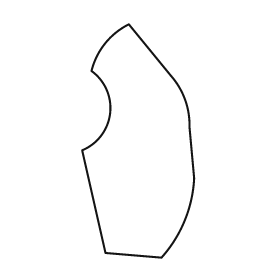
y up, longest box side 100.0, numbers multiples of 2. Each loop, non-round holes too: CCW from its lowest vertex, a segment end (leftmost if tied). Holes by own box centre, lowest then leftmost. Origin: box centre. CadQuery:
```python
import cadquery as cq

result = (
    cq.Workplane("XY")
    .moveTo(10.0, -50.0)
    .threePointArc((20.0, -34.0), (24.0, -16.0))
    .lineTo(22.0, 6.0)
    .threePointArc((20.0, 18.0), (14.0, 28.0))
    .lineTo(-4.0, 50.0)
    .threePointArc((-14.0, 42.0), (-20.0, 30.0))
    .threePointArc((-12.0, 12.0), (-24.0, -4.0))
    .lineTo(-14.0, -48.0)
    .close()
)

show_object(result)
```